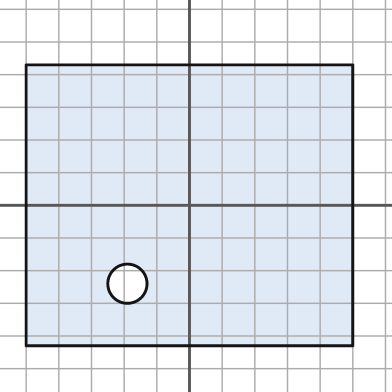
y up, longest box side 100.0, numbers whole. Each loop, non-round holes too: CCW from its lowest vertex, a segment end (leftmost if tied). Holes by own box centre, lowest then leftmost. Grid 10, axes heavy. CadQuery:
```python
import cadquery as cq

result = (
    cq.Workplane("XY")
    .moveTo(-50.0, -43.0)
    .lineTo(50.0, -43.0)
    .lineTo(50.0, 43.0)
    .lineTo(-50.0, 43.0)
    .close()
    .moveTo(-19.0, -24.0)
    .circle(6.0)
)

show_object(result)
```